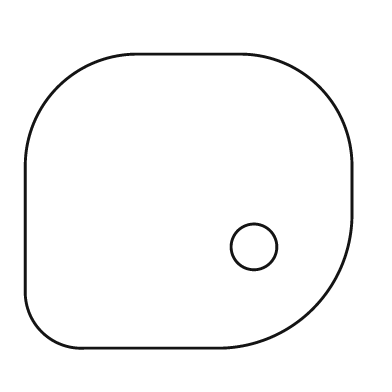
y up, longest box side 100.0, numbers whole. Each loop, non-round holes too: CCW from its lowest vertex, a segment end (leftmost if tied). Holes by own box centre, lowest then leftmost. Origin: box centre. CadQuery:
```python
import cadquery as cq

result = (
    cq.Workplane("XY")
    .moveTo(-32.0, -45.0)
    .lineTo(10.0, -45.0)
    .threePointArc((38.0, -33.0), (50.0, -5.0))
    .lineTo(50.0, 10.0)
    .threePointArc((40.0, 35.0), (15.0, 45.0))
    .lineTo(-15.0, 45.0)
    .threePointArc((-40.0, 35.0), (-50.0, 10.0))
    .lineTo(-50.0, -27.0)
    .threePointArc((-45.0, -40.0), (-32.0, -45.0))
    .close()
    .moveTo(20.0, -14.0)
    .circle(7.0)
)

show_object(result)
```